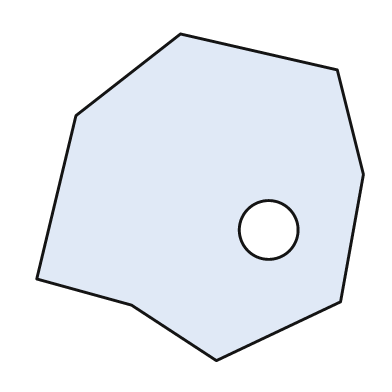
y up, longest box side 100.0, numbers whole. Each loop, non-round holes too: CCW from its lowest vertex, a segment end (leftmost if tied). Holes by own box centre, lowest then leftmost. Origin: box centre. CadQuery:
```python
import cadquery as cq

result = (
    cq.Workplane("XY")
    .moveTo(5.0, -50.0)
    .lineTo(43.0, -32.0)
    .lineTo(50.0, 7.0)
    .lineTo(42.0, 39.0)
    .lineTo(-6.0, 50.0)
    .lineTo(-38.0, 25.0)
    .lineTo(-50.0, -25.0)
    .lineTo(-21.0, -33.0)
    .close()
    .moveTo(21.0, -10.0)
    .circle(9.0)
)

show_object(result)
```